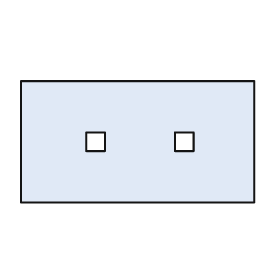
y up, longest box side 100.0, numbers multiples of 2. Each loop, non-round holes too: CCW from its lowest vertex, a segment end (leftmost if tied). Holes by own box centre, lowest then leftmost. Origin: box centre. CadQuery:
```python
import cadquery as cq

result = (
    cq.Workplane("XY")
    .moveTo(-50.0, -26.0)
    .lineTo(50.0, -26.0)
    .lineTo(50.0, 26.0)
    .lineTo(-50.0, 26.0)
    .close()
    .moveTo(-22.0, -4.0)
    .lineTo(-14.0, -4.0)
    .lineTo(-14.0, 4.0)
    .lineTo(-22.0, 4.0)
    .close()
    .moveTo(16.0, -4.0)
    .lineTo(24.0, -4.0)
    .lineTo(24.0, 4.0)
    .lineTo(16.0, 4.0)
    .close()
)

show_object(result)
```